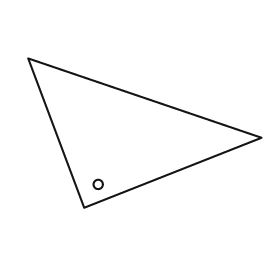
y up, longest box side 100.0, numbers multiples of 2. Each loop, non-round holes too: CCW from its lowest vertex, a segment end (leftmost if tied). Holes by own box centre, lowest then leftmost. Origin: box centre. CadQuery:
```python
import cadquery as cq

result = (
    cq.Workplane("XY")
    .moveTo(-26.0, -32.0)
    .lineTo(50.0, -2.0)
    .lineTo(-50.0, 32.0)
    .close()
    .moveTo(-20.0, -22.0)
    .circle(2.0)
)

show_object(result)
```